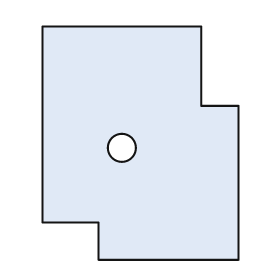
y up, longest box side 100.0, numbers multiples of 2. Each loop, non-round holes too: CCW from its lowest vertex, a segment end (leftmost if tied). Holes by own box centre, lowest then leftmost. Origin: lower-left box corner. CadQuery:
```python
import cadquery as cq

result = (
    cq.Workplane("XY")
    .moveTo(24.0, 0.0)
    .lineTo(84.0, 0.0)
    .lineTo(84.0, 66.0)
    .lineTo(68.0, 66.0)
    .lineTo(68.0, 100.0)
    .lineTo(0.0, 100.0)
    .lineTo(0.0, 16.0)
    .lineTo(24.0, 16.0)
    .close()
    .moveTo(34.0, 48.0)
    .circle(6.0)
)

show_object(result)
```